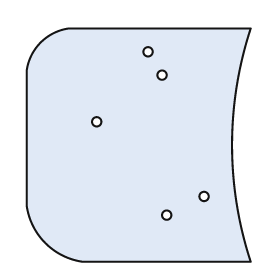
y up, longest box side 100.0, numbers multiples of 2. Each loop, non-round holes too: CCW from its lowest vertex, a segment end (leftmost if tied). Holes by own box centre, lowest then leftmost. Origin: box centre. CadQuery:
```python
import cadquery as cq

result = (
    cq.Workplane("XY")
    .moveTo(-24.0, -50.0)
    .lineTo(48.0, -50.0)
    .threePointArc((40.0, 0.0), (48.0, 50.0))
    .lineTo(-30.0, 50.0)
    .threePointArc((-42.0, 44.0), (-48.0, 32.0))
    .lineTo(-48.0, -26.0)
    .threePointArc((-40.0, -42.0), (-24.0, -50.0))
    .close()
    .moveTo(12.0, -30.0)
    .circle(2.0)
    .moveTo(28.0, -22.0)
    .circle(2.0)
    .moveTo(-18.0, 10.0)
    .circle(2.0)
    .moveTo(10.0, 30.0)
    .circle(2.0)
    .moveTo(4.0, 40.0)
    .circle(2.0)
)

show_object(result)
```